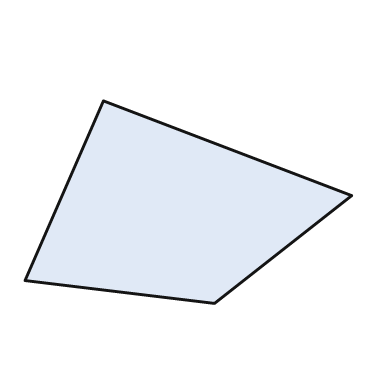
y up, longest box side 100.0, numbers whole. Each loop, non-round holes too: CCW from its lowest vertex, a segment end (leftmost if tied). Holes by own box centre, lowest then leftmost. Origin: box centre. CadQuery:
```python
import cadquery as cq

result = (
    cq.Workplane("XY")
    .moveTo(8.0, -31.0)
    .lineTo(50.0, 2.0)
    .lineTo(-26.0, 31.0)
    .lineTo(-50.0, -24.0)
    .close()
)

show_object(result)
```